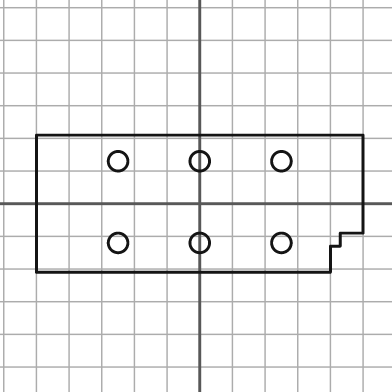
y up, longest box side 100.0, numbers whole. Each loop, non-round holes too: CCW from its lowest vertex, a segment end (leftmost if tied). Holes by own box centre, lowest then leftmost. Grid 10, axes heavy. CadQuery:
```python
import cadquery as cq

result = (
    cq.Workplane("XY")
    .moveTo(-50.0, -21.0)
    .lineTo(40.0, -21.0)
    .lineTo(40.0, -13.0)
    .lineTo(43.0, -13.0)
    .lineTo(43.0, -9.0)
    .lineTo(50.0, -9.0)
    .lineTo(50.0, 21.0)
    .lineTo(-50.0, 21.0)
    .close()
    .moveTo(-25.0, -12.0)
    .circle(3.0)
    .moveTo(0.0, -12.0)
    .circle(3.0)
    .moveTo(25.0, -12.0)
    .circle(3.0)
    .moveTo(-25.0, 13.0)
    .circle(3.0)
    .moveTo(0.0, 13.0)
    .circle(3.0)
    .moveTo(25.0, 13.0)
    .circle(3.0)
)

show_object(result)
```